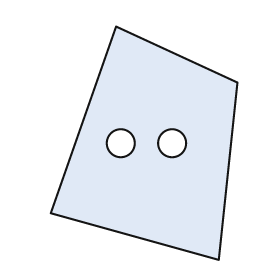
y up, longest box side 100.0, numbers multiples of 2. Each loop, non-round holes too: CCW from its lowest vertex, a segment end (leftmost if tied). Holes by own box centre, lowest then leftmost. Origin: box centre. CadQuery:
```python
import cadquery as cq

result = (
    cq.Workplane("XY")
    .moveTo(32.0, -50.0)
    .lineTo(40.0, 26.0)
    .lineTo(-12.0, 50.0)
    .lineTo(-40.0, -30.0)
    .close()
    .moveTo(-10.0, 0.0)
    .circle(6.0)
    .moveTo(12.0, 0.0)
    .circle(6.0)
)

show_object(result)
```